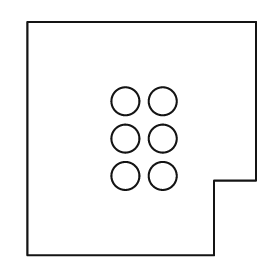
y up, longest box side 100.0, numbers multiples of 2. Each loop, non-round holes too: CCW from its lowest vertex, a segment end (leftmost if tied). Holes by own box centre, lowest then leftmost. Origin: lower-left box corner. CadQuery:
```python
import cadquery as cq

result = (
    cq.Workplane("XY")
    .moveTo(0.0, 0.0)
    .lineTo(80.0, 0.0)
    .lineTo(80.0, 32.0)
    .lineTo(98.0, 32.0)
    .lineTo(98.0, 100.0)
    .lineTo(0.0, 100.0)
    .close()
    .moveTo(42.0, 34.0)
    .circle(6.0)
    .moveTo(58.0, 34.0)
    .circle(6.0)
    .moveTo(42.0, 50.0)
    .circle(6.0)
    .moveTo(58.0, 50.0)
    .circle(6.0)
    .moveTo(42.0, 66.0)
    .circle(6.0)
    .moveTo(58.0, 66.0)
    .circle(6.0)
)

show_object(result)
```